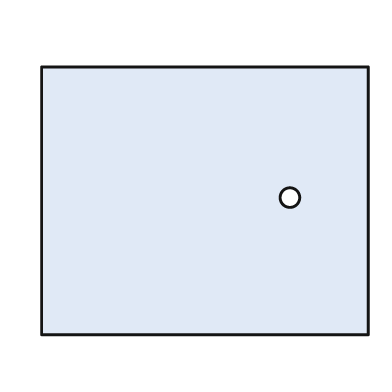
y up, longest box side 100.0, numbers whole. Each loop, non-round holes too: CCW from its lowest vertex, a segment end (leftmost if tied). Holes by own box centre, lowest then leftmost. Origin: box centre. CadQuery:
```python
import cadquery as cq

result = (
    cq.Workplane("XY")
    .moveTo(-50.0, -41.0)
    .lineTo(50.0, -41.0)
    .lineTo(50.0, 41.0)
    .lineTo(-50.0, 41.0)
    .close()
    .moveTo(26.0, 1.0)
    .circle(3.0)
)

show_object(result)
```